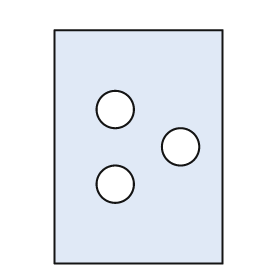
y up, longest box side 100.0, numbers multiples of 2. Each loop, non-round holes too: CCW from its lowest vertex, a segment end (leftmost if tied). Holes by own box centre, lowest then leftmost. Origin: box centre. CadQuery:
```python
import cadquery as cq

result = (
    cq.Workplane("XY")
    .moveTo(-36.0, -50.0)
    .lineTo(36.0, -50.0)
    .lineTo(36.0, 50.0)
    .lineTo(-36.0, 50.0)
    .close()
    .moveTo(-10.0, -16.0)
    .circle(8.0)
    .moveTo(18.0, 0.0)
    .circle(8.0)
    .moveTo(-10.0, 16.0)
    .circle(8.0)
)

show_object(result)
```